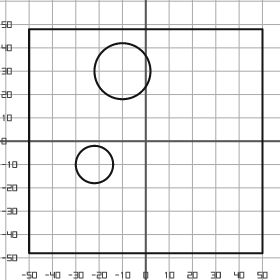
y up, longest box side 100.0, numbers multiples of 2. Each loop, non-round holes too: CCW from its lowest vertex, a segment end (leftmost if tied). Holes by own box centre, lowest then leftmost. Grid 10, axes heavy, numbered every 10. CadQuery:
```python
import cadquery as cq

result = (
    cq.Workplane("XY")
    .moveTo(-50.0, -48.0)
    .lineTo(50.0, -48.0)
    .lineTo(50.0, 48.0)
    .lineTo(-50.0, 48.0)
    .close()
    .moveTo(-22.0, -10.0)
    .circle(8.0)
    .moveTo(-10.0, 30.0)
    .circle(12.0)
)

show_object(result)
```